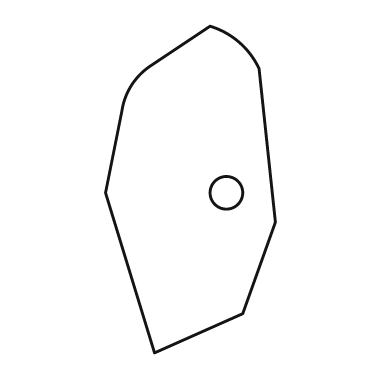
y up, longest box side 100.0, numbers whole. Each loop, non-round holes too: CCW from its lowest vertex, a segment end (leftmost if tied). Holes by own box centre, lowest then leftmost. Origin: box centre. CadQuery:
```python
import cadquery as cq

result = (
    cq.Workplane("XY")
    .moveTo(-11.0, -50.0)
    .lineTo(16.0, -38.0)
    .lineTo(26.0, -10.0)
    .lineTo(21.0, 37.0)
    .threePointArc((15.0, 45.0), (6.0, 50.0))
    .lineTo(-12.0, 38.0)
    .threePointArc((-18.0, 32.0), (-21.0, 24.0))
    .lineTo(-26.0, -1.0)
    .close()
    .moveTo(11.0, -1.0)
    .circle(5.0)
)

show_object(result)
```